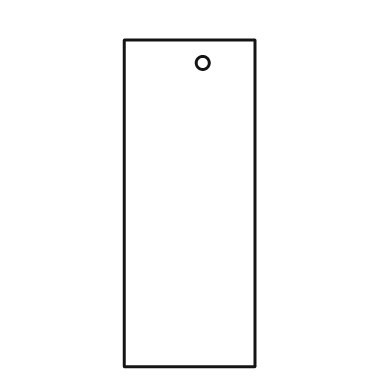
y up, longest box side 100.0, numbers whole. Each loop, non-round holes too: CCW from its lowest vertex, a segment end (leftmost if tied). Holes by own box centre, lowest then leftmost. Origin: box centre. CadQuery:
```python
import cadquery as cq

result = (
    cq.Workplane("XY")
    .moveTo(-20.0, -50.0)
    .lineTo(20.0, -50.0)
    .lineTo(20.0, 50.0)
    .lineTo(-20.0, 50.0)
    .close()
    .moveTo(4.0, 43.0)
    .circle(2.0)
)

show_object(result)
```